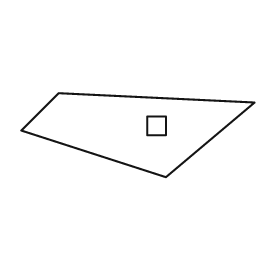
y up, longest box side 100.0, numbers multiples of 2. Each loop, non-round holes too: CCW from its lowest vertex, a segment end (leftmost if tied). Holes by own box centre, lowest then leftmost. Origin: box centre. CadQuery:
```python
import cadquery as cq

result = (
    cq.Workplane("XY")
    .moveTo(12.0, -18.0)
    .lineTo(50.0, 14.0)
    .lineTo(-34.0, 18.0)
    .lineTo(-50.0, 2.0)
    .close()
    .moveTo(4.0, 0.0)
    .lineTo(12.0, 0.0)
    .lineTo(12.0, 8.0)
    .lineTo(4.0, 8.0)
    .close()
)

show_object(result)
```